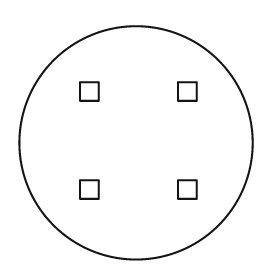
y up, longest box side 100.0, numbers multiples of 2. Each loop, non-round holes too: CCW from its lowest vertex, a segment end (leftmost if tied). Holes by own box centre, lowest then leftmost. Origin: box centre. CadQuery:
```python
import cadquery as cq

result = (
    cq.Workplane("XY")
    .moveTo(0.0, 0.0)
    .circle(50.0)
    .moveTo(-24.0, -24.0)
    .lineTo(-16.0, -24.0)
    .lineTo(-16.0, -16.0)
    .lineTo(-24.0, -16.0)
    .close()
    .moveTo(18.0, -24.0)
    .lineTo(26.0, -24.0)
    .lineTo(26.0, -16.0)
    .lineTo(18.0, -16.0)
    .close()
    .moveTo(-24.0, 18.0)
    .lineTo(-16.0, 18.0)
    .lineTo(-16.0, 26.0)
    .lineTo(-24.0, 26.0)
    .close()
    .moveTo(18.0, 18.0)
    .lineTo(26.0, 18.0)
    .lineTo(26.0, 26.0)
    .lineTo(18.0, 26.0)
    .close()
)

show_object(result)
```